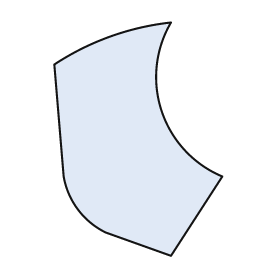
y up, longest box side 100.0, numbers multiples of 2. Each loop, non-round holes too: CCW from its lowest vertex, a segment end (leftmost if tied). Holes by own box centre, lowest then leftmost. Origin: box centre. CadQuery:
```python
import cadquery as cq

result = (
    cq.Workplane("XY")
    .moveTo(14.0, -50.0)
    .lineTo(36.0, -16.0)
    .threePointArc((10.0, 12.0), (14.0, 50.0))
    .threePointArc((-12.0, 44.0), (-36.0, 32.0))
    .lineTo(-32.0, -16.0)
    .threePointArc((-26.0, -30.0), (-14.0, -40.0))
    .close()
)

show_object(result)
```